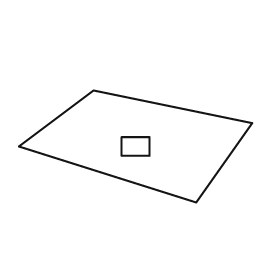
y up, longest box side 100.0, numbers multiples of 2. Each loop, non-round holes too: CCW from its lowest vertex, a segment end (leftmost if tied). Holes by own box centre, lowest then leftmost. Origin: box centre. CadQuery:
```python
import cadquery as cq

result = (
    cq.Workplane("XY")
    .moveTo(26.0, -24.0)
    .lineTo(50.0, 10.0)
    .lineTo(-18.0, 24.0)
    .lineTo(-50.0, 0.0)
    .close()
    .moveTo(-6.0, -4.0)
    .lineTo(6.0, -4.0)
    .lineTo(6.0, 4.0)
    .lineTo(-6.0, 4.0)
    .close()
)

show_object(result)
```